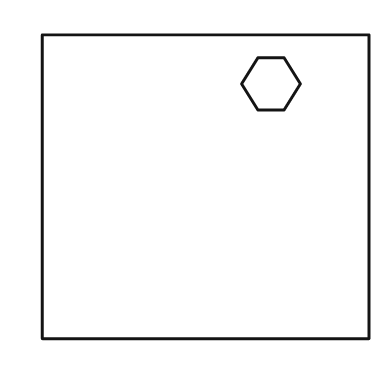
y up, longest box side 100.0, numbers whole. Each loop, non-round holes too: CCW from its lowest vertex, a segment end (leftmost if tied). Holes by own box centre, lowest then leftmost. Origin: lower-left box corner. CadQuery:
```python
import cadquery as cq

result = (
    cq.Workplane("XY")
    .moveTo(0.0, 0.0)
    .lineTo(100.0, 0.0)
    .lineTo(100.0, 93.0)
    .lineTo(0.0, 93.0)
    .close()
    .moveTo(66.0, 70.0)
    .lineTo(74.0, 70.0)
    .lineTo(79.0, 78.0)
    .lineTo(74.0, 86.0)
    .lineTo(66.0, 86.0)
    .lineTo(61.0, 78.0)
    .close()
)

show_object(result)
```